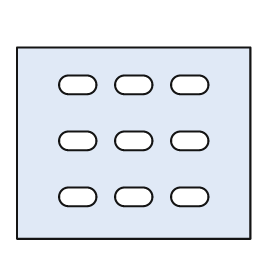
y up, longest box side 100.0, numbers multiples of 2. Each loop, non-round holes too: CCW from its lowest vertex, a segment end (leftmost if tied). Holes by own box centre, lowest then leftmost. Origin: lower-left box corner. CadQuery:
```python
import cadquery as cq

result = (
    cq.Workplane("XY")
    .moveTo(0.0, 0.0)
    .lineTo(100.0, 0.0)
    .lineTo(100.0, 82.0)
    .lineTo(0.0, 82.0)
    .close()
    .moveTo(22.0, 14.0)
    .lineTo(30.0, 14.0)
    .threePointArc((34.0, 18.0), (30.0, 22.0))
    .lineTo(22.0, 22.0)
    .threePointArc((18.0, 18.0), (22.0, 14.0))
    .close()
    .moveTo(46.0, 14.0)
    .lineTo(54.0, 14.0)
    .threePointArc((58.0, 18.0), (54.0, 22.0))
    .lineTo(46.0, 22.0)
    .threePointArc((42.0, 18.0), (46.0, 14.0))
    .close()
    .moveTo(70.0, 14.0)
    .lineTo(78.0, 14.0)
    .threePointArc((82.0, 18.0), (78.0, 22.0))
    .lineTo(70.0, 22.0)
    .threePointArc((66.0, 18.0), (70.0, 14.0))
    .close()
    .moveTo(22.0, 38.0)
    .lineTo(30.0, 38.0)
    .threePointArc((34.0, 42.0), (30.0, 46.0))
    .lineTo(22.0, 46.0)
    .threePointArc((18.0, 42.0), (22.0, 38.0))
    .close()
    .moveTo(46.0, 38.0)
    .lineTo(54.0, 38.0)
    .threePointArc((58.0, 42.0), (54.0, 46.0))
    .lineTo(46.0, 46.0)
    .threePointArc((42.0, 42.0), (46.0, 38.0))
    .close()
    .moveTo(70.0, 38.0)
    .lineTo(78.0, 38.0)
    .threePointArc((82.0, 42.0), (78.0, 46.0))
    .lineTo(70.0, 46.0)
    .threePointArc((66.0, 42.0), (70.0, 38.0))
    .close()
    .moveTo(22.0, 62.0)
    .lineTo(30.0, 62.0)
    .threePointArc((34.0, 66.0), (30.0, 70.0))
    .lineTo(22.0, 70.0)
    .threePointArc((18.0, 66.0), (22.0, 62.0))
    .close()
    .moveTo(46.0, 62.0)
    .lineTo(54.0, 62.0)
    .threePointArc((58.0, 66.0), (54.0, 70.0))
    .lineTo(46.0, 70.0)
    .threePointArc((42.0, 66.0), (46.0, 62.0))
    .close()
    .moveTo(70.0, 62.0)
    .lineTo(78.0, 62.0)
    .threePointArc((82.0, 66.0), (78.0, 70.0))
    .lineTo(70.0, 70.0)
    .threePointArc((66.0, 66.0), (70.0, 62.0))
    .close()
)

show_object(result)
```